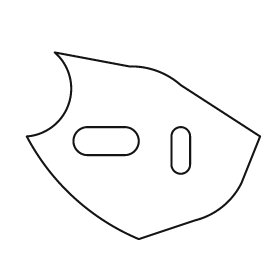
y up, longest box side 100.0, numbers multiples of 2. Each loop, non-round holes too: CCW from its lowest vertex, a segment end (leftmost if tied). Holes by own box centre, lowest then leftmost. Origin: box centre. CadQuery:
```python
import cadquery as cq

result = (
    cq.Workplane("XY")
    .moveTo(-2.0, -40.0)
    .lineTo(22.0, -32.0)
    .threePointArc((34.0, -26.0), (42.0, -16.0))
    .lineTo(50.0, 4.0)
    .lineTo(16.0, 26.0)
    .threePointArc((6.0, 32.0), (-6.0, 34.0))
    .lineTo(-38.0, 40.0)
    .threePointArc((-32.0, 18.0), (-50.0, 4.0))
    .threePointArc((-30.0, -22.0), (-2.0, -40.0))
    .close()
    .moveTo(12.0, -8.0)
    .threePointArc((16.0, -12.0), (20.0, -8.0))
    .lineTo(20.0, 4.0)
    .threePointArc((16.0, 8.0), (12.0, 4.0))
    .close()
    .moveTo(-24.0, -4.0)
    .lineTo(-8.0, -4.0)
    .threePointArc((-2.0, 2.0), (-8.0, 8.0))
    .lineTo(-24.0, 8.0)
    .threePointArc((-30.0, 2.0), (-24.0, -4.0))
    .close()
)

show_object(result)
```